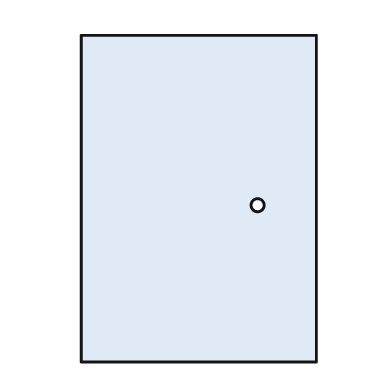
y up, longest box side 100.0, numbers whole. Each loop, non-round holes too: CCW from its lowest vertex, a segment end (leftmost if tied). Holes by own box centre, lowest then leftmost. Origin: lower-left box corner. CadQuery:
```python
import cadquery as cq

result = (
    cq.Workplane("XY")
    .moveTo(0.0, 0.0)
    .lineTo(72.0, 0.0)
    .lineTo(72.0, 100.0)
    .lineTo(0.0, 100.0)
    .close()
    .moveTo(54.0, 48.0)
    .circle(2.0)
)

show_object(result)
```